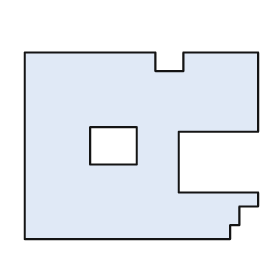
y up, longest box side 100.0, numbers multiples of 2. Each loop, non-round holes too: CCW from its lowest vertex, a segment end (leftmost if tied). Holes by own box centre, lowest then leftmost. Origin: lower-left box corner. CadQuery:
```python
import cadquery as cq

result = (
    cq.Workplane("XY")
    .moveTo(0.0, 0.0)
    .lineTo(88.0, 0.0)
    .lineTo(88.0, 6.0)
    .lineTo(92.0, 6.0)
    .lineTo(92.0, 14.0)
    .lineTo(100.0, 14.0)
    .lineTo(100.0, 20.0)
    .lineTo(66.0, 20.0)
    .lineTo(66.0, 46.0)
    .lineTo(100.0, 46.0)
    .lineTo(100.0, 80.0)
    .lineTo(68.0, 80.0)
    .lineTo(68.0, 72.0)
    .lineTo(56.0, 72.0)
    .lineTo(56.0, 80.0)
    .lineTo(0.0, 80.0)
    .close()
    .moveTo(28.0, 32.0)
    .lineTo(48.0, 32.0)
    .lineTo(48.0, 48.0)
    .lineTo(28.0, 48.0)
    .close()
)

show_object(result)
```